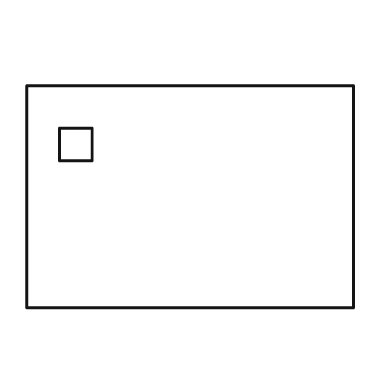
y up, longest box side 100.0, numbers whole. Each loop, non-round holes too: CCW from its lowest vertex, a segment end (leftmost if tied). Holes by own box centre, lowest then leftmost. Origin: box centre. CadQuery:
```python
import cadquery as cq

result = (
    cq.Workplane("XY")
    .moveTo(-50.0, -34.0)
    .lineTo(50.0, -34.0)
    .lineTo(50.0, 34.0)
    .lineTo(-50.0, 34.0)
    .close()
    .moveTo(-40.0, 11.0)
    .lineTo(-30.0, 11.0)
    .lineTo(-30.0, 21.0)
    .lineTo(-40.0, 21.0)
    .close()
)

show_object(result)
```